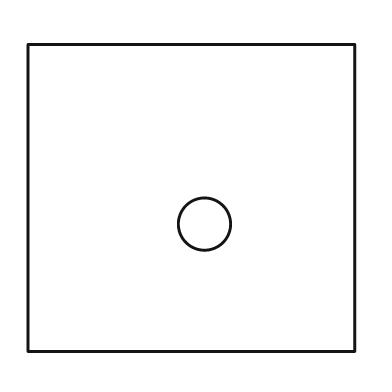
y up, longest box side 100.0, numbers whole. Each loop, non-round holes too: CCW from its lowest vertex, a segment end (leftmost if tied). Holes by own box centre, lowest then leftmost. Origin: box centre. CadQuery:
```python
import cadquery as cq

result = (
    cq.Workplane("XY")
    .moveTo(-50.0, -47.0)
    .lineTo(50.0, -47.0)
    .lineTo(50.0, 47.0)
    .lineTo(-50.0, 47.0)
    .close()
    .moveTo(4.0, -8.0)
    .circle(8.0)
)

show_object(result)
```